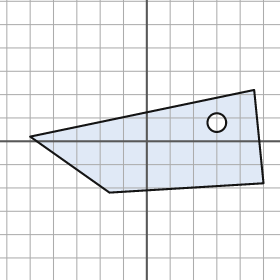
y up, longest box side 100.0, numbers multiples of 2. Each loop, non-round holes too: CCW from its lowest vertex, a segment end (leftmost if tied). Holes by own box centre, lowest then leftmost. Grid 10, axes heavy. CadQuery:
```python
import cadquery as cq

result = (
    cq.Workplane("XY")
    .moveTo(-16.0, -22.0)
    .lineTo(50.0, -18.0)
    .lineTo(46.0, 22.0)
    .lineTo(-50.0, 2.0)
    .close()
    .moveTo(30.0, 8.0)
    .circle(4.0)
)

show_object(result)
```